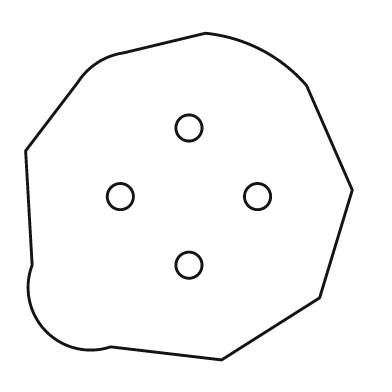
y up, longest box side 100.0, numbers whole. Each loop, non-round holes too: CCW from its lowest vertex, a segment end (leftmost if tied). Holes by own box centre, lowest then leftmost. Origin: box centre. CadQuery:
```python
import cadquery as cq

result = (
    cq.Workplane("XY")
    .moveTo(10.0, -50.0)
    .lineTo(40.0, -31.0)
    .lineTo(50.0, 2.0)
    .lineTo(36.0, 34.0)
    .threePointArc((22.0, 45.0), (5.0, 50.0))
    .lineTo(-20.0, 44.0)
    .threePointArc((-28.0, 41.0), (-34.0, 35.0))
    .lineTo(-50.0, 14.0)
    .lineTo(-48.0, -21.0)
    .threePointArc((-44.0, -41.0), (-24.0, -46.0))
    .close()
    .moveTo(0.0, -21.0)
    .circle(4.0)
    .moveTo(-21.0, 0.0)
    .circle(4.0)
    .moveTo(21.0, 0.0)
    .circle(4.0)
    .moveTo(0.0, 21.0)
    .circle(4.0)
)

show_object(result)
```